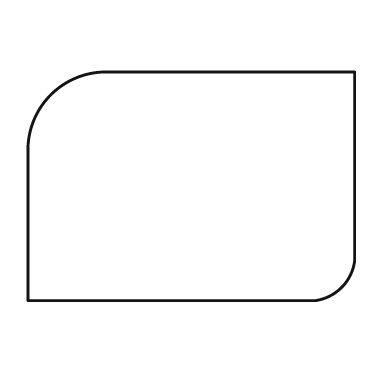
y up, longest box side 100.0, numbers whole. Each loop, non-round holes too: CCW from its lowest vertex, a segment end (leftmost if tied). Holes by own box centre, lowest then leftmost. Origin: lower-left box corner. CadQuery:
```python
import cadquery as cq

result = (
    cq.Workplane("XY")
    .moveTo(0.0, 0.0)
    .lineTo(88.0, 0.0)
    .threePointArc((96.0, 4.0), (100.0, 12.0))
    .lineTo(100.0, 70.0)
    .lineTo(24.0, 70.0)
    .threePointArc((7.0, 63.0), (0.0, 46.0))
    .close()
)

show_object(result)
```